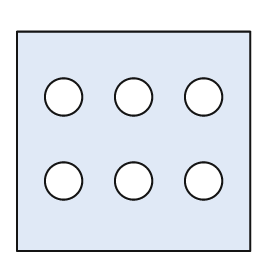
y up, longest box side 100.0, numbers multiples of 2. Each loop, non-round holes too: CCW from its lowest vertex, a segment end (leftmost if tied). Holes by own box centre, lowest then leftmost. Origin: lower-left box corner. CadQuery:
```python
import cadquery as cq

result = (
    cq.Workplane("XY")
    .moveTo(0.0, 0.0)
    .lineTo(100.0, 0.0)
    .lineTo(100.0, 94.0)
    .lineTo(0.0, 94.0)
    .close()
    .moveTo(20.0, 30.0)
    .circle(8.0)
    .moveTo(50.0, 30.0)
    .circle(8.0)
    .moveTo(80.0, 30.0)
    .circle(8.0)
    .moveTo(20.0, 66.0)
    .circle(8.0)
    .moveTo(50.0, 66.0)
    .circle(8.0)
    .moveTo(80.0, 66.0)
    .circle(8.0)
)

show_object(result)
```